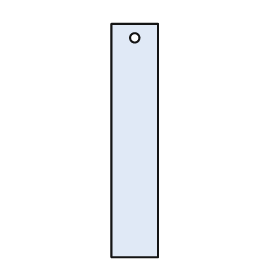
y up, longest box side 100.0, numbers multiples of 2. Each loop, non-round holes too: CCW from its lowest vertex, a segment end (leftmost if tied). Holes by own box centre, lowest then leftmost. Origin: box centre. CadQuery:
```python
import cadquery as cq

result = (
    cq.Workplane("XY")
    .moveTo(-10.0, -50.0)
    .lineTo(10.0, -50.0)
    .lineTo(10.0, 50.0)
    .lineTo(-10.0, 50.0)
    .close()
    .moveTo(0.0, 44.0)
    .circle(2.0)
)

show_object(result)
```